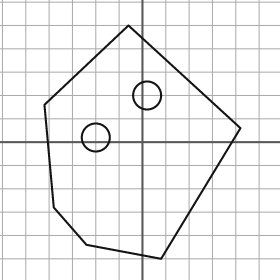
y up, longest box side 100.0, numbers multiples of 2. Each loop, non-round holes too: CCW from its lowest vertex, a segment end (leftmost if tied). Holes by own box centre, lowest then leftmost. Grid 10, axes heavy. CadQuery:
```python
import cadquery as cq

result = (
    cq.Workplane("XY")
    .moveTo(8.0, -50.0)
    .lineTo(42.0, 6.0)
    .lineTo(-6.0, 50.0)
    .lineTo(-42.0, 16.0)
    .lineTo(-38.0, -28.0)
    .lineTo(-24.0, -44.0)
    .close()
    .moveTo(-20.0, 2.0)
    .circle(6.0)
    .moveTo(2.0, 20.0)
    .circle(6.0)
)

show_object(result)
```